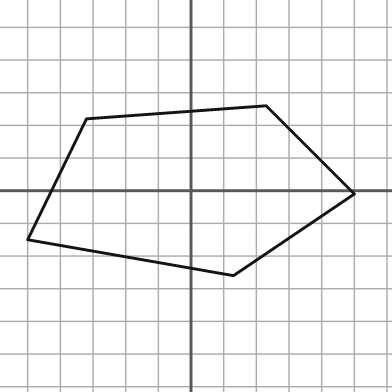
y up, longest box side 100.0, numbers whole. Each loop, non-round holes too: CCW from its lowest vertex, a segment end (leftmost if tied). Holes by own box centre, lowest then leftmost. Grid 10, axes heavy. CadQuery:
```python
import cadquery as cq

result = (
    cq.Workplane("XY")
    .moveTo(13.0, -26.0)
    .lineTo(50.0, -1.0)
    .lineTo(23.0, 26.0)
    .lineTo(-32.0, 22.0)
    .lineTo(-50.0, -15.0)
    .close()
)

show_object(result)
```